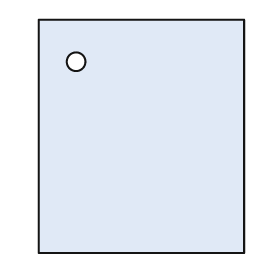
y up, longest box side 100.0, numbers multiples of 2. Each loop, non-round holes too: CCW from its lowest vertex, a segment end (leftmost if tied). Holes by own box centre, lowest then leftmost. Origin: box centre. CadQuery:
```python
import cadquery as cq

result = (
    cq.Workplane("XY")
    .moveTo(-44.0, -50.0)
    .lineTo(44.0, -50.0)
    .lineTo(44.0, 50.0)
    .lineTo(-44.0, 50.0)
    .close()
    .moveTo(-28.0, 32.0)
    .circle(4.0)
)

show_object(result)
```